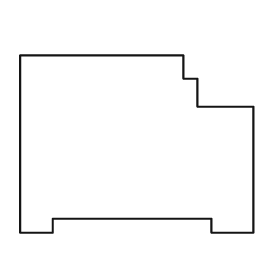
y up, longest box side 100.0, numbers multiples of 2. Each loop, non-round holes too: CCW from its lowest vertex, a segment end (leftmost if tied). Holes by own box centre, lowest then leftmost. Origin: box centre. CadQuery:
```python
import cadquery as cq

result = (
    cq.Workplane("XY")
    .moveTo(-50.0, -38.0)
    .lineTo(-36.0, -38.0)
    .lineTo(-36.0, -32.0)
    .lineTo(32.0, -32.0)
    .lineTo(32.0, -38.0)
    .lineTo(50.0, -38.0)
    .lineTo(50.0, 16.0)
    .lineTo(26.0, 16.0)
    .lineTo(26.0, 28.0)
    .lineTo(20.0, 28.0)
    .lineTo(20.0, 38.0)
    .lineTo(-50.0, 38.0)
    .close()
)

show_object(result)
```